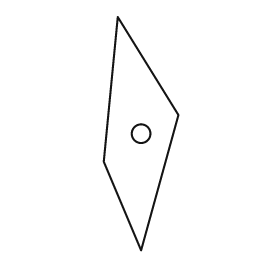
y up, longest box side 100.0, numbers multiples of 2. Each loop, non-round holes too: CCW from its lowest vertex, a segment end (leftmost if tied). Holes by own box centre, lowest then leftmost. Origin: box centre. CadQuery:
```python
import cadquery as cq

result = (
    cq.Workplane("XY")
    .moveTo(0.0, -50.0)
    .lineTo(16.0, 8.0)
    .lineTo(-10.0, 50.0)
    .lineTo(-16.0, -12.0)
    .close()
    .moveTo(0.0, 0.0)
    .circle(4.0)
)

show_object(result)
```